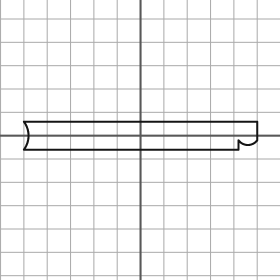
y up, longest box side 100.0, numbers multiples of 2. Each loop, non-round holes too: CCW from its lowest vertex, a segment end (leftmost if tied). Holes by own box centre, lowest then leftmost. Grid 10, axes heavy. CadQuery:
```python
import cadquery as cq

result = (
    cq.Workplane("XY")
    .moveTo(-50.0, -6.0)
    .lineTo(42.0, -6.0)
    .lineTo(42.0, -2.0)
    .threePointArc((46.0, -4.0), (50.0, -2.0))
    .lineTo(50.0, 6.0)
    .lineTo(-50.0, 6.0)
    .threePointArc((-48.0, 0.0), (-50.0, -6.0))
    .close()
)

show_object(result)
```